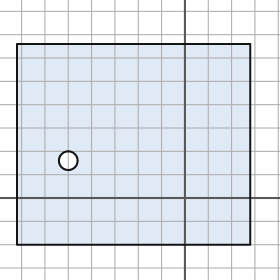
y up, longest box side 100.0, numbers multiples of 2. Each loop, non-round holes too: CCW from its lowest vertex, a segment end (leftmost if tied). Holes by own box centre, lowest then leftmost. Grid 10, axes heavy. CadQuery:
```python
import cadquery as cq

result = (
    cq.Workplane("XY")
    .moveTo(-72.0, -20.0)
    .lineTo(28.0, -20.0)
    .lineTo(28.0, 66.0)
    .lineTo(-72.0, 66.0)
    .close()
    .moveTo(-50.0, 16.0)
    .circle(4.0)
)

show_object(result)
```